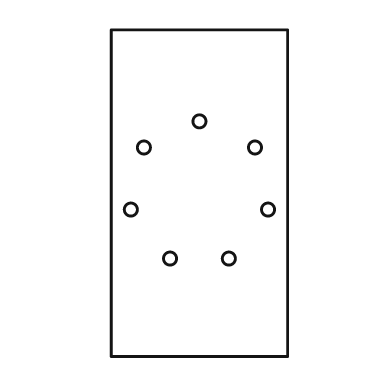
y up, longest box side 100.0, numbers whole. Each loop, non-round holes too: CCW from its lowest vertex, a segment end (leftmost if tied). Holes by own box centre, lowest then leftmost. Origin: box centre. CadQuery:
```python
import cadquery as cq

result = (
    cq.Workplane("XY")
    .moveTo(-27.0, -50.0)
    .lineTo(27.0, -50.0)
    .lineTo(27.0, 50.0)
    .lineTo(-27.0, 50.0)
    .close()
    .moveTo(-9.0, -20.0)
    .circle(2.0)
    .moveTo(9.0, -20.0)
    .circle(2.0)
    .moveTo(-21.0, -5.0)
    .circle(2.0)
    .moveTo(21.0, -5.0)
    .circle(2.0)
    .moveTo(-17.0, 14.0)
    .circle(2.0)
    .moveTo(17.0, 14.0)
    .circle(2.0)
    .moveTo(0.0, 22.0)
    .circle(2.0)
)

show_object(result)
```